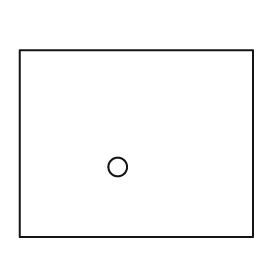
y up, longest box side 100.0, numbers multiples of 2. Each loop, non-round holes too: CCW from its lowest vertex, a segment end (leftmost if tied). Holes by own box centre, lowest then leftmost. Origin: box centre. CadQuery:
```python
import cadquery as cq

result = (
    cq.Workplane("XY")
    .moveTo(-50.0, -40.0)
    .lineTo(50.0, -40.0)
    .lineTo(50.0, 40.0)
    .lineTo(-50.0, 40.0)
    .close()
    .moveTo(-8.0, -10.0)
    .circle(4.0)
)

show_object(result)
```